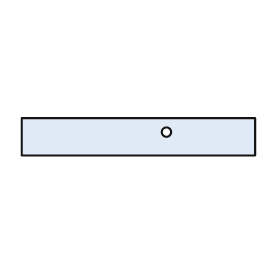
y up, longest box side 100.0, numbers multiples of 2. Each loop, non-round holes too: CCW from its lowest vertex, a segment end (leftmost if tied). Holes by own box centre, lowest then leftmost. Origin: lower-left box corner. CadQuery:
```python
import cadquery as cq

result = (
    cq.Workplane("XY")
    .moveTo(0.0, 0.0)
    .lineTo(100.0, 0.0)
    .lineTo(100.0, 16.0)
    .lineTo(0.0, 16.0)
    .close()
    .moveTo(62.0, 10.0)
    .circle(2.0)
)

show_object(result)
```